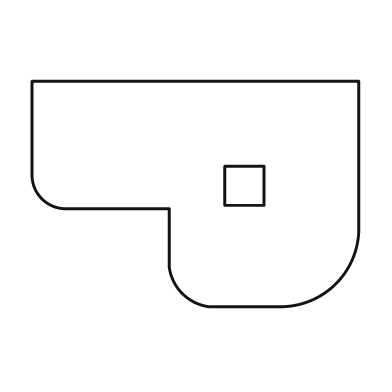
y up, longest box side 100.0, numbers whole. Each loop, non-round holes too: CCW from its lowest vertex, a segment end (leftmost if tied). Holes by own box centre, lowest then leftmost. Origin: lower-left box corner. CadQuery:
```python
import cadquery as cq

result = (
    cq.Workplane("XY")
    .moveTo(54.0, 0.0)
    .lineTo(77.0, 0.0)
    .threePointArc((93.0, 7.0), (100.0, 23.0))
    .lineTo(100.0, 69.0)
    .lineTo(0.0, 69.0)
    .lineTo(0.0, 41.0)
    .threePointArc((3.0, 33.0), (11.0, 30.0))
    .lineTo(42.0, 30.0)
    .lineTo(42.0, 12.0)
    .threePointArc((46.0, 4.0), (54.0, 0.0))
    .close()
    .moveTo(59.0, 31.0)
    .lineTo(71.0, 31.0)
    .lineTo(71.0, 43.0)
    .lineTo(59.0, 43.0)
    .close()
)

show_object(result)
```